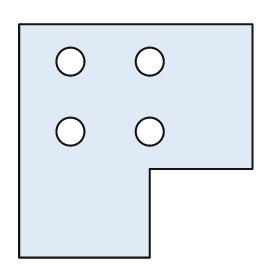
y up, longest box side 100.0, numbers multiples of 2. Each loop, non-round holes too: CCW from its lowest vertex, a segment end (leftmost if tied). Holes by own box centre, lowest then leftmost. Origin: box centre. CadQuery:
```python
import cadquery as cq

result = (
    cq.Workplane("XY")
    .moveTo(-50.0, -50.0)
    .lineTo(6.0, -50.0)
    .lineTo(6.0, -12.0)
    .lineTo(50.0, -12.0)
    .lineTo(50.0, 50.0)
    .lineTo(-50.0, 50.0)
    .close()
    .moveTo(-28.0, 4.0)
    .circle(6.0)
    .moveTo(6.0, 4.0)
    .circle(6.0)
    .moveTo(-28.0, 34.0)
    .circle(6.0)
    .moveTo(6.0, 34.0)
    .circle(6.0)
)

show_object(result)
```